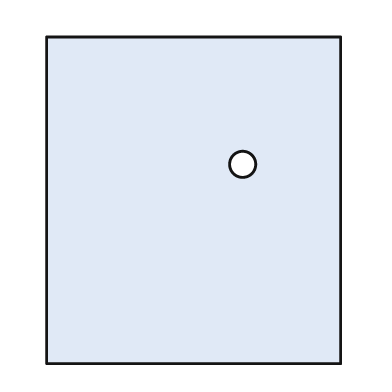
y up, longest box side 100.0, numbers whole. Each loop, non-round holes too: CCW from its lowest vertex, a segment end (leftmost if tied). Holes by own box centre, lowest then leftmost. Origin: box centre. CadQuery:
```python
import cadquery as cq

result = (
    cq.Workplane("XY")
    .moveTo(-45.0, -50.0)
    .lineTo(45.0, -50.0)
    .lineTo(45.0, 50.0)
    .lineTo(-45.0, 50.0)
    .close()
    .moveTo(15.0, 11.0)
    .circle(4.0)
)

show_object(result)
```